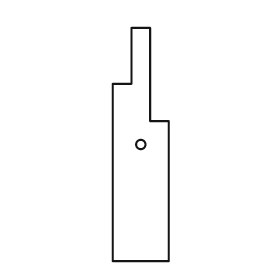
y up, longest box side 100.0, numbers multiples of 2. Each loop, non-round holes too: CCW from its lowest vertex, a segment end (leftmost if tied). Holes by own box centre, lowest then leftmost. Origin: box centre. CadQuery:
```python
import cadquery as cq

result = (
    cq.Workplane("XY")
    .moveTo(-12.0, -50.0)
    .lineTo(12.0, -50.0)
    .lineTo(12.0, 10.0)
    .lineTo(4.0, 10.0)
    .lineTo(4.0, 50.0)
    .lineTo(-4.0, 50.0)
    .lineTo(-4.0, 26.0)
    .lineTo(-12.0, 26.0)
    .close()
    .moveTo(0.0, 0.0)
    .circle(2.0)
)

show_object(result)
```